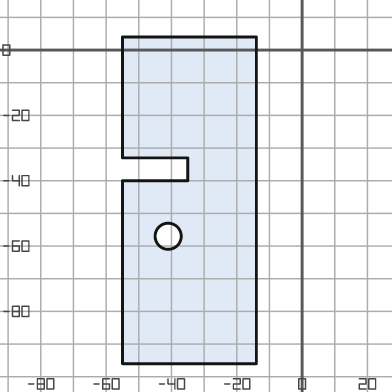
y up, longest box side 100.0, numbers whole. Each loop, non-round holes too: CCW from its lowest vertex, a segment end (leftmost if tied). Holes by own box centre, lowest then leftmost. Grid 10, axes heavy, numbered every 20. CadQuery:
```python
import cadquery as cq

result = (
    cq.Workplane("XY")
    .moveTo(-55.0, -96.0)
    .lineTo(-14.0, -96.0)
    .lineTo(-14.0, 4.0)
    .lineTo(-55.0, 4.0)
    .lineTo(-55.0, -33.0)
    .lineTo(-35.0, -33.0)
    .lineTo(-35.0, -40.0)
    .lineTo(-55.0, -40.0)
    .close()
    .moveTo(-41.0, -57.0)
    .circle(4.0)
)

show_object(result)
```